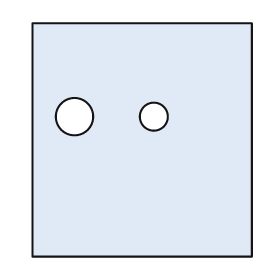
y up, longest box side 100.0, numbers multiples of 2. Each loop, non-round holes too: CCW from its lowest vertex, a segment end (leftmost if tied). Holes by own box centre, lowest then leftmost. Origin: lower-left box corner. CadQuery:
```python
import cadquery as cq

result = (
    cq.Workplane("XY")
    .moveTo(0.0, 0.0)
    .lineTo(94.0, 0.0)
    .lineTo(94.0, 100.0)
    .lineTo(0.0, 100.0)
    .close()
    .moveTo(18.0, 60.0)
    .circle(8.0)
    .moveTo(52.0, 60.0)
    .circle(6.0)
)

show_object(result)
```